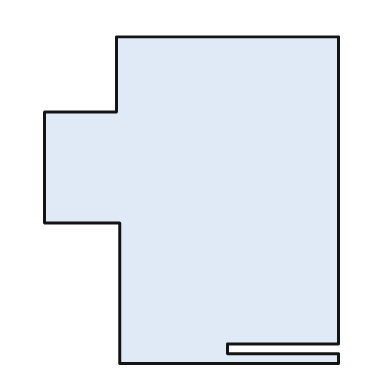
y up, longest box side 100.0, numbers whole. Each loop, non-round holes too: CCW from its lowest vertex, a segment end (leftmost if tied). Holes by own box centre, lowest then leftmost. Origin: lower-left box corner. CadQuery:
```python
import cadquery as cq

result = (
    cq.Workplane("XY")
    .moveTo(23.0, 0.0)
    .lineTo(90.0, 0.0)
    .lineTo(90.0, 3.0)
    .lineTo(56.0, 3.0)
    .lineTo(56.0, 6.0)
    .lineTo(90.0, 6.0)
    .lineTo(90.0, 100.0)
    .lineTo(22.0, 100.0)
    .lineTo(22.0, 77.0)
    .lineTo(0.0, 77.0)
    .lineTo(0.0, 43.0)
    .lineTo(23.0, 43.0)
    .close()
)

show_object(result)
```